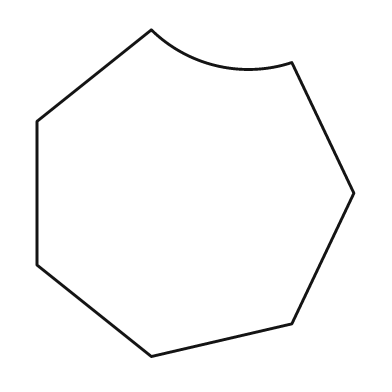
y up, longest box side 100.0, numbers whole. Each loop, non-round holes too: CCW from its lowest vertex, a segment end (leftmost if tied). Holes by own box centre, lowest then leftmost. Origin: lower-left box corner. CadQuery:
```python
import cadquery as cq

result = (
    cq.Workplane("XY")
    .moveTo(35.0, 0.0)
    .lineTo(78.0, 10.0)
    .lineTo(97.0, 50.0)
    .lineTo(78.0, 90.0)
    .threePointArc((55.0, 89.0), (35.0, 100.0))
    .lineTo(0.0, 72.0)
    .lineTo(0.0, 28.0)
    .close()
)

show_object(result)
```